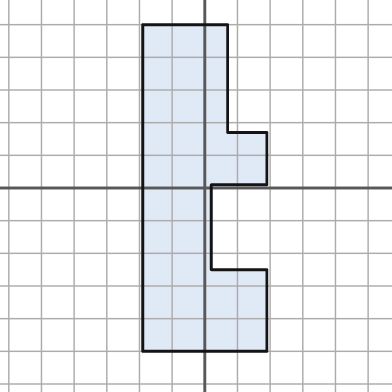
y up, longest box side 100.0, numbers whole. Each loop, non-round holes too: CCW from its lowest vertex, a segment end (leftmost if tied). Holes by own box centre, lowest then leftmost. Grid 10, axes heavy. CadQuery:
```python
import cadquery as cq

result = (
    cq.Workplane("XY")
    .moveTo(-19.0, -50.0)
    .lineTo(19.0, -50.0)
    .lineTo(19.0, -25.0)
    .lineTo(2.0, -25.0)
    .lineTo(2.0, 1.0)
    .lineTo(19.0, 1.0)
    .lineTo(19.0, 17.0)
    .lineTo(7.0, 17.0)
    .lineTo(7.0, 50.0)
    .lineTo(-19.0, 50.0)
    .close()
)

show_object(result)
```